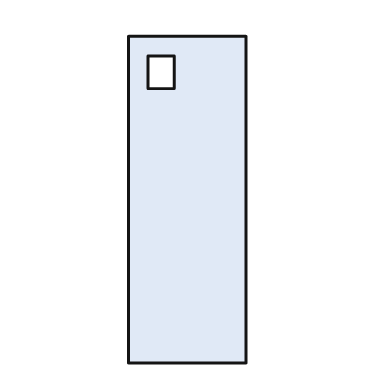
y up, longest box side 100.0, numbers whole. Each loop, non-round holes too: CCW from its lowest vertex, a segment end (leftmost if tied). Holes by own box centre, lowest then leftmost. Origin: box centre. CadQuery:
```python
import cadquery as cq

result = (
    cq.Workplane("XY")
    .moveTo(-18.0, -50.0)
    .lineTo(18.0, -50.0)
    .lineTo(18.0, 50.0)
    .lineTo(-18.0, 50.0)
    .close()
    .moveTo(-12.0, 34.0)
    .lineTo(-4.0, 34.0)
    .lineTo(-4.0, 44.0)
    .lineTo(-12.0, 44.0)
    .close()
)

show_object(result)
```